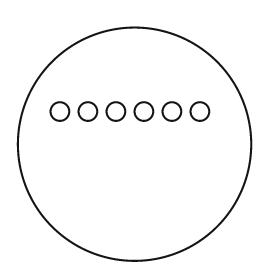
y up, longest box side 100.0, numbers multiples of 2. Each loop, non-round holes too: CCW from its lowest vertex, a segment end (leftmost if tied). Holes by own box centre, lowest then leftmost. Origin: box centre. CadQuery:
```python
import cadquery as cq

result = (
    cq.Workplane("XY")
    .moveTo(0.0, 0.0)
    .circle(50.0)
    .moveTo(-32.0, 14.0)
    .circle(4.0)
    .moveTo(-20.0, 14.0)
    .circle(4.0)
    .moveTo(-8.0, 14.0)
    .circle(4.0)
    .moveTo(4.0, 14.0)
    .circle(4.0)
    .moveTo(16.0, 14.0)
    .circle(4.0)
    .moveTo(28.0, 14.0)
    .circle(4.0)
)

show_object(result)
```